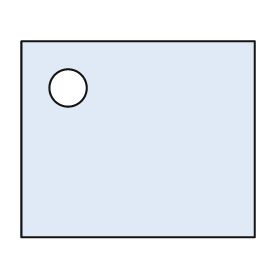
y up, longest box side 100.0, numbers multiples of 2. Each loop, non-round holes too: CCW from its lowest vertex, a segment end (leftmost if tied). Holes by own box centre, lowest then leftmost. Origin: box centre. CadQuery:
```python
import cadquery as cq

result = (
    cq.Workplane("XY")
    .moveTo(-50.0, -42.0)
    .lineTo(50.0, -42.0)
    .lineTo(50.0, 42.0)
    .lineTo(-50.0, 42.0)
    .close()
    .moveTo(-30.0, 22.0)
    .circle(8.0)
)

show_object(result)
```